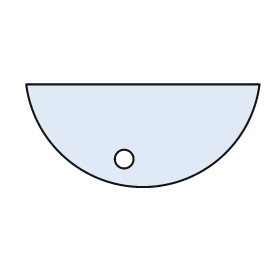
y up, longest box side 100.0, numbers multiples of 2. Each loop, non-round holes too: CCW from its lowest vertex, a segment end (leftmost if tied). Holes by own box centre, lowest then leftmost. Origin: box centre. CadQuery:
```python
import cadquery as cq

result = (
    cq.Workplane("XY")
    .moveTo(-50.0, 22.0)
    .threePointArc((0.0, -22.0), (50.0, 22.0))
    .close()
    .moveTo(-8.0, -10.0)
    .circle(4.0)
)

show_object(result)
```